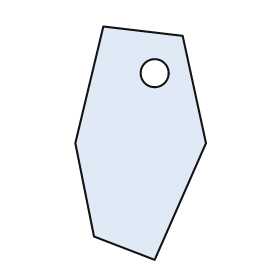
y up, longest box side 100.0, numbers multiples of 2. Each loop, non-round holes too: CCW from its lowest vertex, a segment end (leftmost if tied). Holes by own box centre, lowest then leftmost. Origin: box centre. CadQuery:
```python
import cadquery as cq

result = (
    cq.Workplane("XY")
    .moveTo(6.0, -50.0)
    .lineTo(28.0, 0.0)
    .lineTo(18.0, 46.0)
    .lineTo(-16.0, 50.0)
    .lineTo(-28.0, 0.0)
    .lineTo(-20.0, -40.0)
    .close()
    .moveTo(6.0, 30.0)
    .circle(6.0)
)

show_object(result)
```